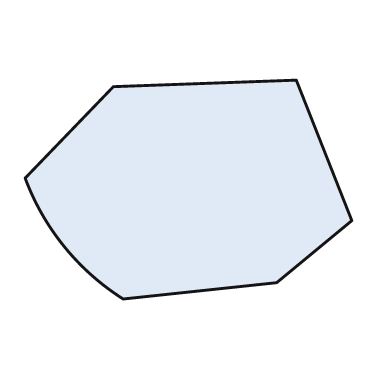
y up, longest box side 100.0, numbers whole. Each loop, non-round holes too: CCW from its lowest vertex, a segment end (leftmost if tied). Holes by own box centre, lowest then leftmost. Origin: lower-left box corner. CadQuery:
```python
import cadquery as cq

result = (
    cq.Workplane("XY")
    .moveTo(30.0, 0.0)
    .lineTo(77.0, 5.0)
    .lineTo(100.0, 24.0)
    .lineTo(83.0, 67.0)
    .lineTo(27.0, 65.0)
    .lineTo(0.0, 37.0)
    .threePointArc((12.0, 16.0), (30.0, 0.0))
    .close()
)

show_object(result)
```